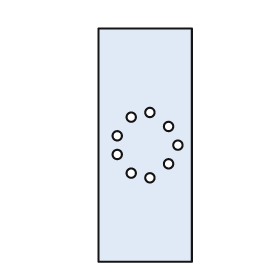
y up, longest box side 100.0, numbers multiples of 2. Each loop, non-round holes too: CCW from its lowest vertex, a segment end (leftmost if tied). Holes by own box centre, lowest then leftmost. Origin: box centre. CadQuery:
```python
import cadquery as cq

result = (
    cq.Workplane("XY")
    .moveTo(-20.0, -50.0)
    .lineTo(20.0, -50.0)
    .lineTo(20.0, 50.0)
    .lineTo(-20.0, 50.0)
    .close()
    .moveTo(2.0, -14.0)
    .circle(2.0)
    .moveTo(-6.0, -12.0)
    .circle(2.0)
    .moveTo(10.0, -8.0)
    .circle(2.0)
    .moveTo(-12.0, -4.0)
    .circle(2.0)
    .moveTo(14.0, 0.0)
    .circle(2.0)
    .moveTo(-12.0, 4.0)
    .circle(2.0)
    .moveTo(10.0, 8.0)
    .circle(2.0)
    .moveTo(-6.0, 12.0)
    .circle(2.0)
    .moveTo(2.0, 14.0)
    .circle(2.0)
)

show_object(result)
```